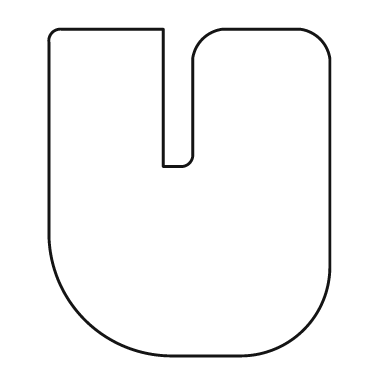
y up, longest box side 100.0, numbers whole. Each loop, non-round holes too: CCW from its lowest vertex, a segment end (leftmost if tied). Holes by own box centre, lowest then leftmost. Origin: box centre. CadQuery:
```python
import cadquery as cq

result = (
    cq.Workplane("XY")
    .moveTo(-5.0, -50.0)
    .lineTo(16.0, -50.0)
    .threePointArc((35.0, -42.0), (43.0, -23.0))
    .lineTo(43.0, 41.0)
    .threePointArc((40.0, 47.0), (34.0, 50.0))
    .lineTo(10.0, 50.0)
    .threePointArc((4.0, 47.0), (1.0, 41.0))
    .lineTo(1.0, 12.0)
    .threePointArc((0.0, 9.0), (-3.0, 8.0))
    .lineTo(-8.0, 8.0)
    .lineTo(-8.0, 50.0)
    .lineTo(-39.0, 50.0)
    .threePointArc((-42.0, 49.0), (-43.0, 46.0))
    .lineTo(-43.0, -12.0)
    .threePointArc((-32.0, -39.0), (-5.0, -50.0))
    .close()
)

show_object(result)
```